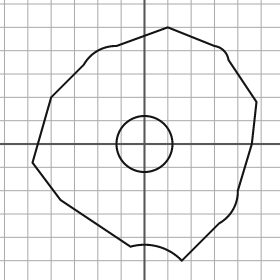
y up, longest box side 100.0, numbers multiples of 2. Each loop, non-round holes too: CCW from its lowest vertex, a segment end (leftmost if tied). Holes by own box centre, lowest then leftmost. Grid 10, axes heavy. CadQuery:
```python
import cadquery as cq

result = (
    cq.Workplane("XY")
    .moveTo(16.0, -50.0)
    .lineTo(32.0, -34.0)
    .threePointArc((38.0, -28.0), (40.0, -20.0))
    .lineTo(46.0, 0.0)
    .lineTo(48.0, 18.0)
    .lineTo(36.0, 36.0)
    .threePointArc((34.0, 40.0), (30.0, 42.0))
    .lineTo(10.0, 50.0)
    .lineTo(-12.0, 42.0)
    .threePointArc((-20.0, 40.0), (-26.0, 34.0))
    .lineTo(-40.0, 20.0)
    .lineTo(-48.0, -8.0)
    .lineTo(-36.0, -24.0)
    .lineTo(-6.0, -44.0)
    .threePointArc((6.0, -44.0), (16.0, -50.0))
    .close()
    .moveTo(0.0, 0.0)
    .circle(12.0)
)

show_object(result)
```